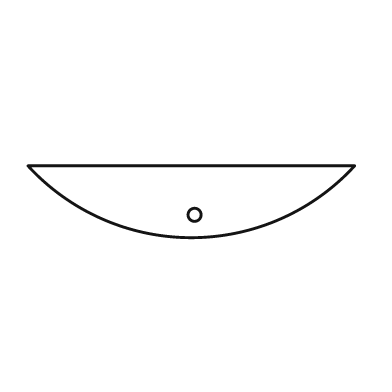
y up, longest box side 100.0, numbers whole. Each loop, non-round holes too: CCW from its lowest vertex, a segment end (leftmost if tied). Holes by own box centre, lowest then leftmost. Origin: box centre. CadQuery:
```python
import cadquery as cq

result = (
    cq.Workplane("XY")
    .moveTo(-50.0, 11.0)
    .threePointArc((0.0, -11.0), (50.0, 11.0))
    .close()
    .moveTo(1.0, -4.0)
    .circle(2.0)
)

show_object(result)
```